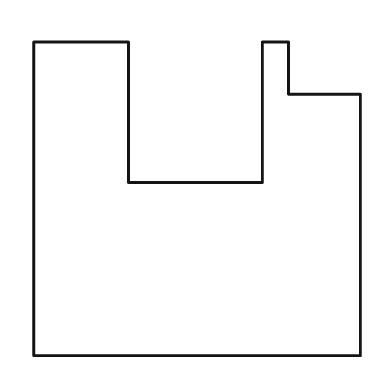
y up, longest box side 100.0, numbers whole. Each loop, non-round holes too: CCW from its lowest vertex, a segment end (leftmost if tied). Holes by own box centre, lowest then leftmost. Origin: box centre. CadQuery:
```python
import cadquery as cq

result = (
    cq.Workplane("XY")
    .moveTo(-50.0, -48.0)
    .lineTo(50.0, -48.0)
    .lineTo(50.0, 32.0)
    .lineTo(28.0, 32.0)
    .lineTo(28.0, 48.0)
    .lineTo(20.0, 48.0)
    .lineTo(20.0, 5.0)
    .lineTo(-21.0, 5.0)
    .lineTo(-21.0, 48.0)
    .lineTo(-50.0, 48.0)
    .close()
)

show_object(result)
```